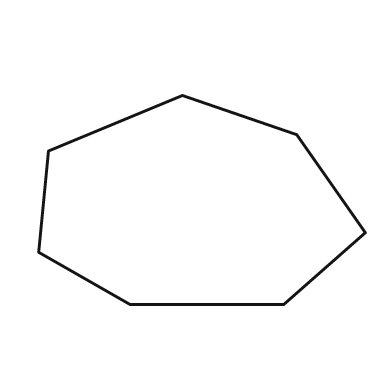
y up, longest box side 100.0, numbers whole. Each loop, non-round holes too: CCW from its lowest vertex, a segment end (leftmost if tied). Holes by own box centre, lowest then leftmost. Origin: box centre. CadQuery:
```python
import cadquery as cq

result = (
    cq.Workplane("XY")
    .moveTo(-22.0, -32.0)
    .lineTo(25.0, -32.0)
    .lineTo(50.0, -10.0)
    .lineTo(29.0, 20.0)
    .lineTo(-6.0, 32.0)
    .lineTo(-47.0, 15.0)
    .lineTo(-50.0, -16.0)
    .close()
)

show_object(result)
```